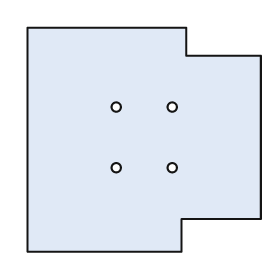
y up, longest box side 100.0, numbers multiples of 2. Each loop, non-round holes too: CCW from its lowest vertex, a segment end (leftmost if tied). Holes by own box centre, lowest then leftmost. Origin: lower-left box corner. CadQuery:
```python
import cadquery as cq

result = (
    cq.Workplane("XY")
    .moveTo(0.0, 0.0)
    .lineTo(66.0, 0.0)
    .lineTo(66.0, 14.0)
    .lineTo(100.0, 14.0)
    .lineTo(100.0, 84.0)
    .lineTo(68.0, 84.0)
    .lineTo(68.0, 96.0)
    .lineTo(0.0, 96.0)
    .close()
    .moveTo(38.0, 36.0)
    .circle(2.0)
    .moveTo(62.0, 36.0)
    .circle(2.0)
    .moveTo(38.0, 62.0)
    .circle(2.0)
    .moveTo(62.0, 62.0)
    .circle(2.0)
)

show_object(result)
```